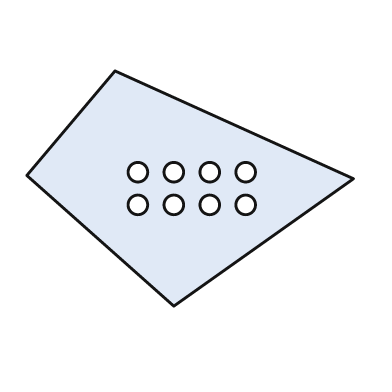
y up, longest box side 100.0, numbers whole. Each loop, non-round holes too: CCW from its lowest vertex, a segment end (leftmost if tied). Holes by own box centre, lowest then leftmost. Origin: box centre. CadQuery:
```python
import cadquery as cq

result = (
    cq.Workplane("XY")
    .moveTo(-5.0, -36.0)
    .lineTo(50.0, 3.0)
    .lineTo(-23.0, 36.0)
    .lineTo(-50.0, 4.0)
    .close()
    .moveTo(-16.0, -5.0)
    .circle(3.0)
    .moveTo(-5.0, -5.0)
    .circle(3.0)
    .moveTo(6.0, -5.0)
    .circle(3.0)
    .moveTo(17.0, -5.0)
    .circle(3.0)
    .moveTo(-16.0, 5.0)
    .circle(3.0)
    .moveTo(-5.0, 5.0)
    .circle(3.0)
    .moveTo(6.0, 5.0)
    .circle(3.0)
    .moveTo(17.0, 5.0)
    .circle(3.0)
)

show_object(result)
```